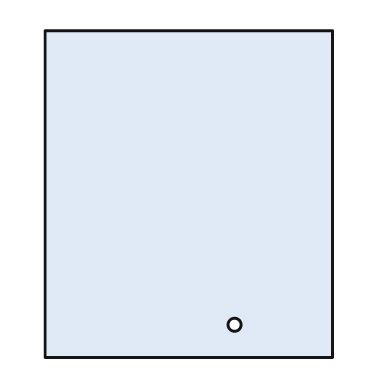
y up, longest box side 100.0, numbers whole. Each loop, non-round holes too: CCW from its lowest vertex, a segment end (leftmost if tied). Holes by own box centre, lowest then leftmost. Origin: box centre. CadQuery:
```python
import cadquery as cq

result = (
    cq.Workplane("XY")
    .moveTo(-44.0, -50.0)
    .lineTo(44.0, -50.0)
    .lineTo(44.0, 50.0)
    .lineTo(-44.0, 50.0)
    .close()
    .moveTo(14.0, -40.0)
    .circle(2.0)
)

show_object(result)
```